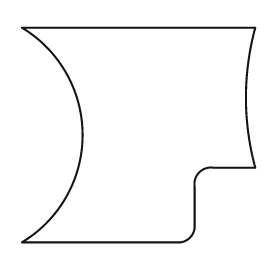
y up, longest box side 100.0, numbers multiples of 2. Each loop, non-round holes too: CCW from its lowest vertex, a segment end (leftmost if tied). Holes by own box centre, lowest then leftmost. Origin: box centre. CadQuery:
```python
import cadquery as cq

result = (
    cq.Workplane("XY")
    .moveTo(-50.0, -46.0)
    .lineTo(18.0, -46.0)
    .threePointArc((22.0, -44.0), (24.0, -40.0))
    .lineTo(24.0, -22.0)
    .threePointArc((26.0, -16.0), (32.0, -14.0))
    .lineTo(50.0, -14.0)
    .threePointArc((46.0, 16.0), (50.0, 46.0))
    .lineTo(-50.0, 46.0)
    .threePointArc((-24.0, 0.0), (-50.0, -46.0))
    .close()
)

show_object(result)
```